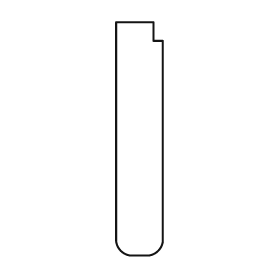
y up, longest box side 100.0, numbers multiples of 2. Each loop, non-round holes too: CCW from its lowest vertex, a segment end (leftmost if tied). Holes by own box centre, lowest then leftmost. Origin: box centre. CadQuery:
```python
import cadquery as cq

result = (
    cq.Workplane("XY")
    .moveTo(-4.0, -50.0)
    .lineTo(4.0, -50.0)
    .threePointArc((8.0, -48.0), (10.0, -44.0))
    .lineTo(10.0, 42.0)
    .lineTo(6.0, 42.0)
    .lineTo(6.0, 50.0)
    .lineTo(-10.0, 50.0)
    .lineTo(-10.0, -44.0)
    .threePointArc((-8.0, -48.0), (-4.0, -50.0))
    .close()
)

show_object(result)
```